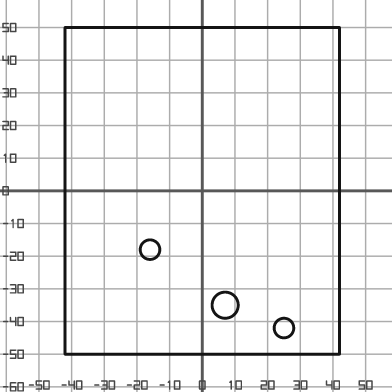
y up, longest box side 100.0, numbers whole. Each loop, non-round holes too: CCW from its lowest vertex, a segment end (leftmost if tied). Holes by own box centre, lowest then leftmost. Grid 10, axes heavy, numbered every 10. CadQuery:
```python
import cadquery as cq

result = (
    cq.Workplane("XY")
    .moveTo(-42.0, -50.0)
    .lineTo(42.0, -50.0)
    .lineTo(42.0, 50.0)
    .lineTo(-42.0, 50.0)
    .close()
    .moveTo(25.0, -42.0)
    .circle(3.0)
    .moveTo(7.0, -35.0)
    .circle(4.0)
    .moveTo(-16.0, -18.0)
    .circle(3.0)
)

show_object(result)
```